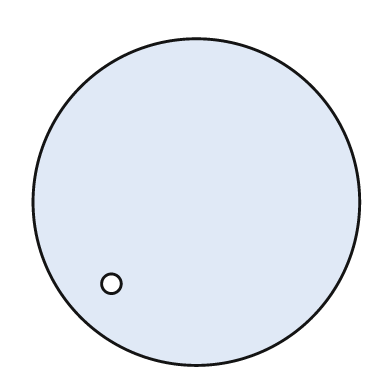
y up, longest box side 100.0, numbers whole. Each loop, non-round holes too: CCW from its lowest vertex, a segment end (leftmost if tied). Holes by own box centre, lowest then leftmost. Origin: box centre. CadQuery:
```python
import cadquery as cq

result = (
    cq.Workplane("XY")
    .moveTo(0.0, 0.0)
    .circle(50.0)
    .moveTo(-26.0, -25.0)
    .circle(3.0)
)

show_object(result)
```